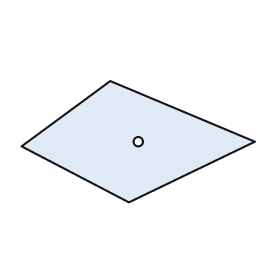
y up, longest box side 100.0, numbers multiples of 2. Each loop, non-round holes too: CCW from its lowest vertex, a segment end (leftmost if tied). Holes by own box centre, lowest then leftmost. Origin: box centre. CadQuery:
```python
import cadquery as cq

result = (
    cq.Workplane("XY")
    .moveTo(-4.0, -26.0)
    .lineTo(50.0, 0.0)
    .lineTo(-12.0, 26.0)
    .lineTo(-50.0, -2.0)
    .close()
    .moveTo(0.0, 0.0)
    .circle(2.0)
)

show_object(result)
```